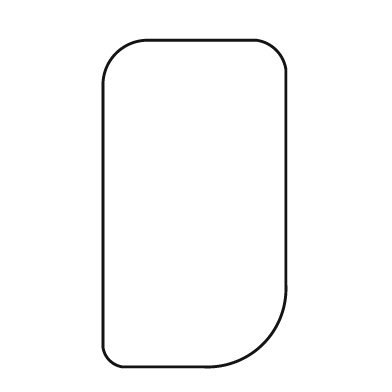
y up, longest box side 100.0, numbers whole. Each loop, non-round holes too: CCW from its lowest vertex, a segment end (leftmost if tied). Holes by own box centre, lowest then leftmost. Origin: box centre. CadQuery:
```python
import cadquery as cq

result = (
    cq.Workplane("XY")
    .moveTo(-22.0, -50.0)
    .lineTo(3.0, -50.0)
    .threePointArc((21.0, -43.0), (28.0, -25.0))
    .lineTo(28.0, 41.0)
    .threePointArc((25.0, 47.0), (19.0, 50.0))
    .lineTo(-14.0, 50.0)
    .threePointArc((-24.0, 46.0), (-28.0, 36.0))
    .lineTo(-28.0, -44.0)
    .threePointArc((-26.0, -48.0), (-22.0, -50.0))
    .close()
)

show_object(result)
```